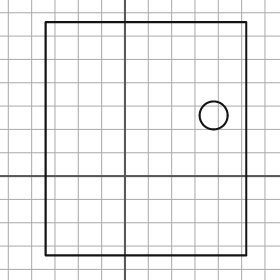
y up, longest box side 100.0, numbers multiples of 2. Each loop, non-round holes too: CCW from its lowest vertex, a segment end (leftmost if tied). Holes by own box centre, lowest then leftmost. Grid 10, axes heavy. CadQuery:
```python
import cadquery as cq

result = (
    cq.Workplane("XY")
    .moveTo(-34.0, -34.0)
    .lineTo(52.0, -34.0)
    .lineTo(52.0, 66.0)
    .lineTo(-34.0, 66.0)
    .close()
    .moveTo(38.0, 26.0)
    .circle(6.0)
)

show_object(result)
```